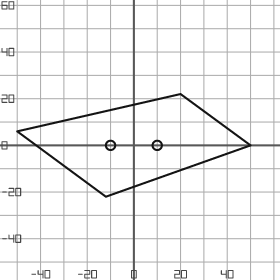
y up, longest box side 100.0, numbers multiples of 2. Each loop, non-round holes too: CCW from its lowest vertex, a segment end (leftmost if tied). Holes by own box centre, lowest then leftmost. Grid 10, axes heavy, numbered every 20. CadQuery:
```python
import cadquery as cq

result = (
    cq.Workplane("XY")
    .moveTo(-12.0, -22.0)
    .lineTo(50.0, 0.0)
    .lineTo(20.0, 22.0)
    .lineTo(-50.0, 6.0)
    .close()
    .moveTo(-10.0, 0.0)
    .circle(2.0)
    .moveTo(10.0, 0.0)
    .circle(2.0)
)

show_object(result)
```